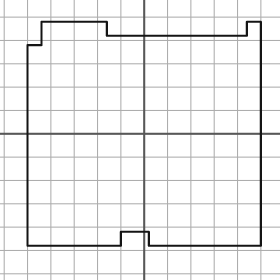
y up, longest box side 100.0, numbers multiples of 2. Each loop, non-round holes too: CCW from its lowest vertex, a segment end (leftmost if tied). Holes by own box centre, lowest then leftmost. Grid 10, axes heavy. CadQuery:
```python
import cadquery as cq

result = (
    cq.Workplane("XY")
    .moveTo(-50.0, -48.0)
    .lineTo(-10.0, -48.0)
    .lineTo(-10.0, -42.0)
    .lineTo(2.0, -42.0)
    .lineTo(2.0, -48.0)
    .lineTo(50.0, -48.0)
    .lineTo(50.0, 48.0)
    .lineTo(44.0, 48.0)
    .lineTo(44.0, 42.0)
    .lineTo(-16.0, 42.0)
    .lineTo(-16.0, 48.0)
    .lineTo(-44.0, 48.0)
    .lineTo(-44.0, 38.0)
    .lineTo(-50.0, 38.0)
    .close()
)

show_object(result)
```